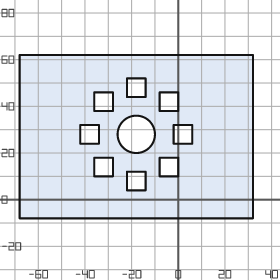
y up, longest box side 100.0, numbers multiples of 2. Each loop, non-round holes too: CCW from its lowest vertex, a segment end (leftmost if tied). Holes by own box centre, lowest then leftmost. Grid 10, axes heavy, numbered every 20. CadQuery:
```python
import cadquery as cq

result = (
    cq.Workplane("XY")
    .moveTo(-68.0, -8.0)
    .lineTo(32.0, -8.0)
    .lineTo(32.0, 62.0)
    .lineTo(-68.0, 62.0)
    .close()
    .moveTo(-22.0, 4.0)
    .lineTo(-14.0, 4.0)
    .lineTo(-14.0, 12.0)
    .lineTo(-22.0, 12.0)
    .close()
    .moveTo(-36.0, 10.0)
    .lineTo(-28.0, 10.0)
    .lineTo(-28.0, 18.0)
    .lineTo(-36.0, 18.0)
    .close()
    .moveTo(-8.0, 10.0)
    .lineTo(0.0, 10.0)
    .lineTo(0.0, 18.0)
    .lineTo(-8.0, 18.0)
    .close()
    .moveTo(-42.0, 24.0)
    .lineTo(-34.0, 24.0)
    .lineTo(-34.0, 32.0)
    .lineTo(-42.0, 32.0)
    .close()
    .moveTo(-18.0, 28.0)
    .circle(8.0)
    .moveTo(-2.0, 24.0)
    .lineTo(6.0, 24.0)
    .lineTo(6.0, 32.0)
    .lineTo(-2.0, 32.0)
    .close()
    .moveTo(-36.0, 38.0)
    .lineTo(-28.0, 38.0)
    .lineTo(-28.0, 46.0)
    .lineTo(-36.0, 46.0)
    .close()
    .moveTo(-8.0, 38.0)
    .lineTo(0.0, 38.0)
    .lineTo(0.0, 46.0)
    .lineTo(-8.0, 46.0)
    .close()
    .moveTo(-22.0, 44.0)
    .lineTo(-14.0, 44.0)
    .lineTo(-14.0, 52.0)
    .lineTo(-22.0, 52.0)
    .close()
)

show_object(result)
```